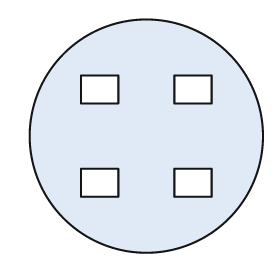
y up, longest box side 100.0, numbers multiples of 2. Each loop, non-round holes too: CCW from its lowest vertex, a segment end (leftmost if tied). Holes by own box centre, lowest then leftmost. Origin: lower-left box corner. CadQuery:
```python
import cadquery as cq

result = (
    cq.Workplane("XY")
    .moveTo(50.0, 50.0)
    .circle(50.0)
    .moveTo(22.0, 24.0)
    .lineTo(38.0, 24.0)
    .lineTo(38.0, 36.0)
    .lineTo(22.0, 36.0)
    .close()
    .moveTo(62.0, 24.0)
    .lineTo(78.0, 24.0)
    .lineTo(78.0, 36.0)
    .lineTo(62.0, 36.0)
    .close()
    .moveTo(22.0, 64.0)
    .lineTo(38.0, 64.0)
    .lineTo(38.0, 76.0)
    .lineTo(22.0, 76.0)
    .close()
    .moveTo(62.0, 64.0)
    .lineTo(78.0, 64.0)
    .lineTo(78.0, 76.0)
    .lineTo(62.0, 76.0)
    .close()
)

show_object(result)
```